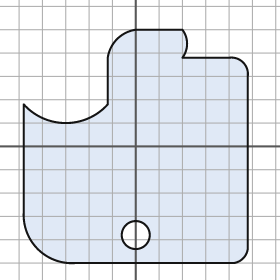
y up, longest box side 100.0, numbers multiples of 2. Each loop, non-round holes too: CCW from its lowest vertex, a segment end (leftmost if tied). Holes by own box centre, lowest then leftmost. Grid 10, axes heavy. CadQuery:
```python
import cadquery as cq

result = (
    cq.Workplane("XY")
    .moveTo(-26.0, -50.0)
    .lineTo(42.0, -50.0)
    .threePointArc((46.0, -48.0), (48.0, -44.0))
    .lineTo(48.0, 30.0)
    .threePointArc((46.0, 36.0), (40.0, 38.0))
    .lineTo(20.0, 38.0)
    .threePointArc((22.0, 44.0), (20.0, 50.0))
    .lineTo(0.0, 50.0)
    .threePointArc((-8.0, 46.0), (-12.0, 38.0))
    .lineTo(-12.0, 18.0)
    .threePointArc((-30.0, 10.0), (-48.0, 18.0))
    .lineTo(-48.0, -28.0)
    .threePointArc((-42.0, -44.0), (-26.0, -50.0))
    .close()
    .moveTo(0.0, -38.0)
    .circle(6.0)
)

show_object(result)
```